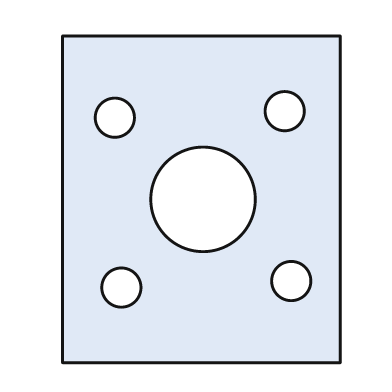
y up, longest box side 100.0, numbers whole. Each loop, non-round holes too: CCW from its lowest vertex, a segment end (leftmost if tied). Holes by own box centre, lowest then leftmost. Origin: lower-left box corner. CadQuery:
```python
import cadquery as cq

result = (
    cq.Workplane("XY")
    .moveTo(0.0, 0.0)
    .lineTo(85.0, 0.0)
    .lineTo(85.0, 100.0)
    .lineTo(0.0, 100.0)
    .close()
    .moveTo(18.0, 23.0)
    .circle(6.0)
    .moveTo(70.0, 25.0)
    .circle(6.0)
    .moveTo(43.0, 50.0)
    .circle(16.0)
    .moveTo(16.0, 75.0)
    .circle(6.0)
    .moveTo(68.0, 77.0)
    .circle(6.0)
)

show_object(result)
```